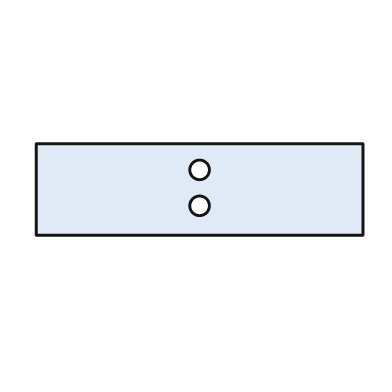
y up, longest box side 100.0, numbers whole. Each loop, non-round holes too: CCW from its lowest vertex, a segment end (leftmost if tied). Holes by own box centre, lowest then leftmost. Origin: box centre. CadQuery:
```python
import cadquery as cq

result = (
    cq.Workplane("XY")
    .moveTo(-50.0, -14.0)
    .lineTo(50.0, -14.0)
    .lineTo(50.0, 14.0)
    .lineTo(-50.0, 14.0)
    .close()
    .moveTo(0.0, -5.0)
    .circle(3.0)
    .moveTo(0.0, 6.0)
    .circle(3.0)
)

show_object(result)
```